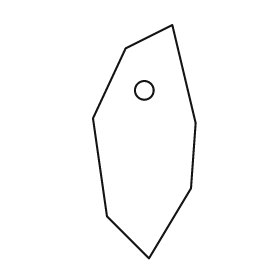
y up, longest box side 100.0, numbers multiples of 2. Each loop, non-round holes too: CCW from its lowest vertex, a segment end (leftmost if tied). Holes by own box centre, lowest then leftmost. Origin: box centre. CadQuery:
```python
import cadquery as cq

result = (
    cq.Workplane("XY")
    .moveTo(2.0, -50.0)
    .lineTo(20.0, -20.0)
    .lineTo(22.0, 8.0)
    .lineTo(12.0, 50.0)
    .lineTo(-8.0, 40.0)
    .lineTo(-22.0, 10.0)
    .lineTo(-16.0, -32.0)
    .close()
    .moveTo(0.0, 22.0)
    .circle(4.0)
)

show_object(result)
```